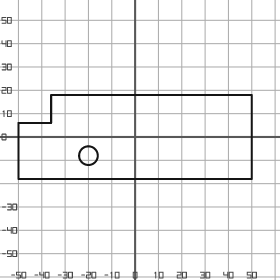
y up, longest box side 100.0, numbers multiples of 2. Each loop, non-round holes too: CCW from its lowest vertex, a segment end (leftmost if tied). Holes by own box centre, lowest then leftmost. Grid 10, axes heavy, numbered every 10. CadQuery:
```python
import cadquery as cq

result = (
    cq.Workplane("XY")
    .moveTo(-50.0, -18.0)
    .lineTo(50.0, -18.0)
    .lineTo(50.0, 18.0)
    .lineTo(-36.0, 18.0)
    .lineTo(-36.0, 6.0)
    .lineTo(-50.0, 6.0)
    .close()
    .moveTo(-20.0, -8.0)
    .circle(4.0)
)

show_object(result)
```